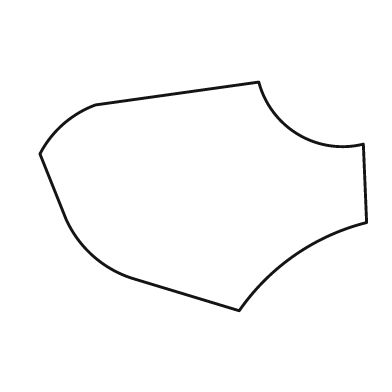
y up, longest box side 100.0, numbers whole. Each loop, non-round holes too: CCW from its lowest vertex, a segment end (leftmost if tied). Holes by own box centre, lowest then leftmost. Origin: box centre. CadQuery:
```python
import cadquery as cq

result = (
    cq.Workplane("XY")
    .moveTo(11.0, -35.0)
    .threePointArc((28.0, -18.0), (50.0, -8.0))
    .lineTo(49.0, 16.0)
    .threePointArc((29.0, 19.0), (17.0, 35.0))
    .lineTo(-33.0, 28.0)
    .threePointArc((-43.0, 22.0), (-50.0, 13.0))
    .lineTo(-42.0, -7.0)
    .threePointArc((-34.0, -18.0), (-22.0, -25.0))
    .close()
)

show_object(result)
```